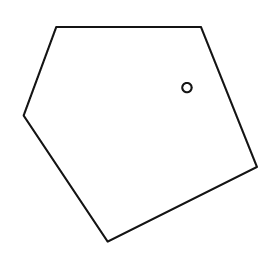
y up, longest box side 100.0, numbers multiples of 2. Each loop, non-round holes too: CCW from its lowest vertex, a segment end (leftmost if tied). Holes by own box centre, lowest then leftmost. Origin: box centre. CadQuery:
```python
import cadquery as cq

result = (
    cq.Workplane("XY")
    .moveTo(-14.0, -46.0)
    .lineTo(50.0, -14.0)
    .lineTo(26.0, 46.0)
    .lineTo(-36.0, 46.0)
    .lineTo(-50.0, 8.0)
    .close()
    .moveTo(20.0, 20.0)
    .circle(2.0)
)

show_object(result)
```